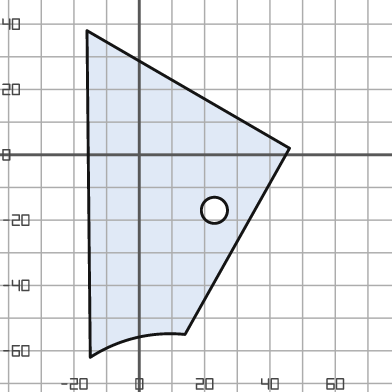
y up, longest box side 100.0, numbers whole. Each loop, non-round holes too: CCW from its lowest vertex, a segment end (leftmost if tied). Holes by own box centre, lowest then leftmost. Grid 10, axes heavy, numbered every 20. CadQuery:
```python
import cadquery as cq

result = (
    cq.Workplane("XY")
    .moveTo(-15.0, -62.0)
    .threePointArc((-1.0, -56.0), (14.0, -55.0))
    .lineTo(46.0, 2.0)
    .lineTo(-16.0, 38.0)
    .close()
    .moveTo(23.0, -17.0)
    .circle(4.0)
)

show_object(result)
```